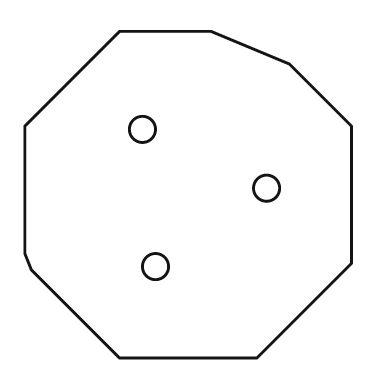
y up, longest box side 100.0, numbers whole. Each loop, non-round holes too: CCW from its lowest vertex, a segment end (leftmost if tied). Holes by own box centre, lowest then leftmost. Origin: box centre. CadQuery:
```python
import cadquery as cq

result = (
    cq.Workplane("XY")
    .moveTo(-21.0, -50.0)
    .lineTo(21.0, -50.0)
    .lineTo(50.0, -21.0)
    .lineTo(50.0, 21.0)
    .lineTo(31.0, 40.0)
    .lineTo(7.0, 50.0)
    .lineTo(-21.0, 50.0)
    .lineTo(-50.0, 21.0)
    .lineTo(-50.0, -18.0)
    .lineTo(-48.0, -23.0)
    .close()
    .moveTo(-10.0, -22.0)
    .circle(4.0)
    .moveTo(24.0, 2.0)
    .circle(4.0)
    .moveTo(-14.0, 20.0)
    .circle(4.0)
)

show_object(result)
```